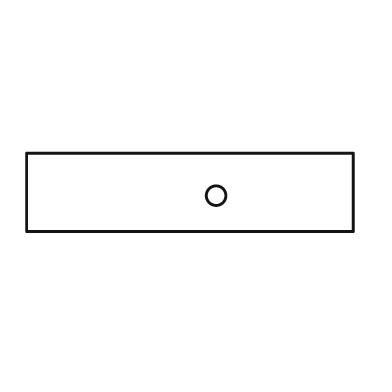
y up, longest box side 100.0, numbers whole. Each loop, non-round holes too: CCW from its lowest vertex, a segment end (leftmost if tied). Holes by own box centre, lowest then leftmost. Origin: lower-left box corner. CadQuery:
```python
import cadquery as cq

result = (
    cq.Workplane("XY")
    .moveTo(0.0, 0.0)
    .lineTo(100.0, 0.0)
    .lineTo(100.0, 24.0)
    .lineTo(0.0, 24.0)
    .close()
    .moveTo(58.0, 11.0)
    .circle(3.0)
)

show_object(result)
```